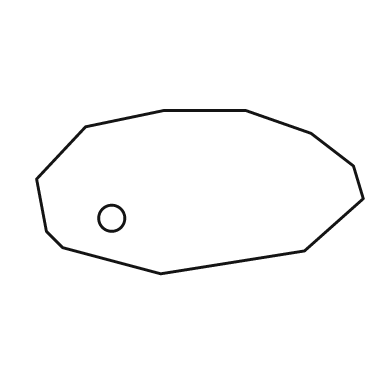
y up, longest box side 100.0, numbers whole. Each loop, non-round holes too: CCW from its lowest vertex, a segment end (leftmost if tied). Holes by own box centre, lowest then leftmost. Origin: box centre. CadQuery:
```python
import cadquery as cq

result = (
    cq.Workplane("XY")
    .moveTo(-12.0, -25.0)
    .lineTo(32.0, -18.0)
    .lineTo(50.0, -2.0)
    .lineTo(47.0, 8.0)
    .lineTo(34.0, 18.0)
    .lineTo(14.0, 25.0)
    .lineTo(-11.0, 25.0)
    .lineTo(-35.0, 20.0)
    .lineTo(-50.0, 4.0)
    .lineTo(-47.0, -12.0)
    .lineTo(-42.0, -17.0)
    .close()
    .moveTo(-27.0, -8.0)
    .circle(4.0)
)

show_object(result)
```